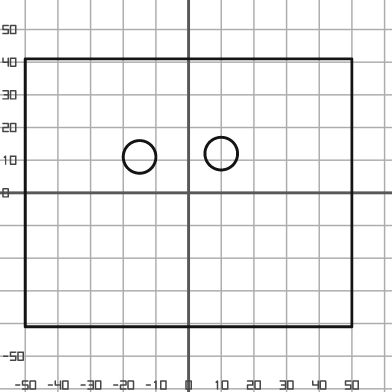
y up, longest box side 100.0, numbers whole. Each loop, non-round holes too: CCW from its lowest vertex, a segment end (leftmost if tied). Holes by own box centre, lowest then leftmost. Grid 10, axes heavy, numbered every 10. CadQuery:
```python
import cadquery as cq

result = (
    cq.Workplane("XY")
    .moveTo(-50.0, -41.0)
    .lineTo(50.0, -41.0)
    .lineTo(50.0, 41.0)
    .lineTo(-50.0, 41.0)
    .close()
    .moveTo(-15.0, 11.0)
    .circle(5.0)
    .moveTo(10.0, 12.0)
    .circle(5.0)
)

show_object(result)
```